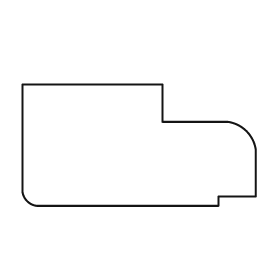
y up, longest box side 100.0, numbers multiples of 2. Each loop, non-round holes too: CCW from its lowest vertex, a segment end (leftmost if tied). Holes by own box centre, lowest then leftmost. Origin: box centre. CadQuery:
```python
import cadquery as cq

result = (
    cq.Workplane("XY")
    .moveTo(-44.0, -26.0)
    .lineTo(34.0, -26.0)
    .lineTo(34.0, -22.0)
    .lineTo(50.0, -22.0)
    .lineTo(50.0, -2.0)
    .threePointArc((46.0, 6.0), (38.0, 10.0))
    .lineTo(10.0, 10.0)
    .lineTo(10.0, 26.0)
    .lineTo(-50.0, 26.0)
    .lineTo(-50.0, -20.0)
    .threePointArc((-48.0, -24.0), (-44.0, -26.0))
    .close()
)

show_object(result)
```